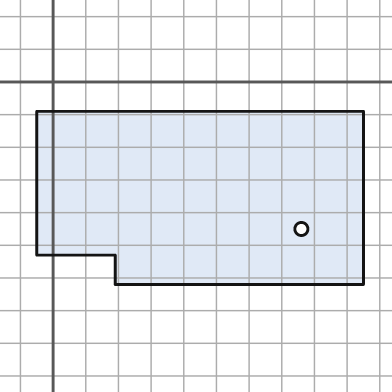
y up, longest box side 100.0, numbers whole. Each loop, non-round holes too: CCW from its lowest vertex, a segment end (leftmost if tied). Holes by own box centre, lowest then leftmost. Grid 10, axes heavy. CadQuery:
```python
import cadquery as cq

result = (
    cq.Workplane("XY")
    .moveTo(19.0, -62.0)
    .lineTo(95.0, -62.0)
    .lineTo(95.0, -9.0)
    .lineTo(-5.0, -9.0)
    .lineTo(-5.0, -53.0)
    .lineTo(19.0, -53.0)
    .close()
    .moveTo(76.0, -45.0)
    .circle(2.0)
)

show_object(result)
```